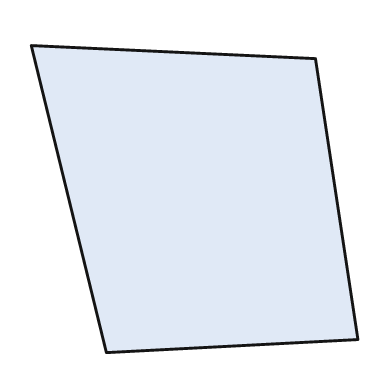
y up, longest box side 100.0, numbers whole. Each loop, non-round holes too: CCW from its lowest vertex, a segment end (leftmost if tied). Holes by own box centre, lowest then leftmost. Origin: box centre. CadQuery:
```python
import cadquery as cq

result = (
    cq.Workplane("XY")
    .moveTo(-27.0, -47.0)
    .lineTo(50.0, -43.0)
    .lineTo(37.0, 43.0)
    .lineTo(-50.0, 47.0)
    .close()
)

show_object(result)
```